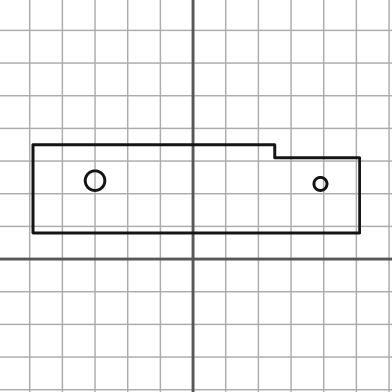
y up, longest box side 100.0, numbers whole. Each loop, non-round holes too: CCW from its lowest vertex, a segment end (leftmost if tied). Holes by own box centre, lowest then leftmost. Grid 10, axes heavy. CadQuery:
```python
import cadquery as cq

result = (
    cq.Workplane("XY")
    .moveTo(-49.0, 8.0)
    .lineTo(51.0, 8.0)
    .lineTo(51.0, 31.0)
    .lineTo(25.0, 31.0)
    .lineTo(25.0, 35.0)
    .lineTo(-49.0, 35.0)
    .close()
    .moveTo(39.0, 23.0)
    .circle(2.0)
    .moveTo(-30.0, 24.0)
    .circle(3.0)
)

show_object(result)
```